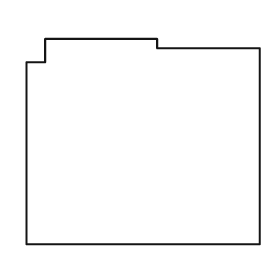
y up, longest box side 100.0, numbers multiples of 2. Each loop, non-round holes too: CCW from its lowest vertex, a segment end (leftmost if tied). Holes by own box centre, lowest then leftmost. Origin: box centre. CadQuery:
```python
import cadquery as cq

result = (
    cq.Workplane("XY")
    .moveTo(-50.0, -44.0)
    .lineTo(50.0, -44.0)
    .lineTo(50.0, 40.0)
    .lineTo(6.0, 40.0)
    .lineTo(6.0, 44.0)
    .lineTo(-42.0, 44.0)
    .lineTo(-42.0, 34.0)
    .lineTo(-50.0, 34.0)
    .close()
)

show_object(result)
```